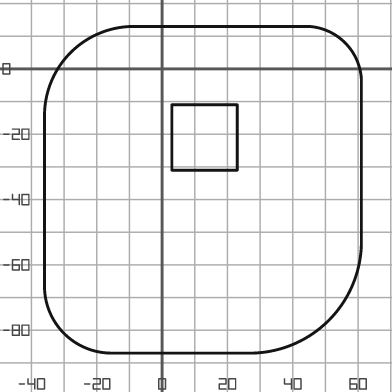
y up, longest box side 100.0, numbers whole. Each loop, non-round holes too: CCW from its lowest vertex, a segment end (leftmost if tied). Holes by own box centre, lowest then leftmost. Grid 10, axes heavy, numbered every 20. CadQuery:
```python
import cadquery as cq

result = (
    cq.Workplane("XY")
    .moveTo(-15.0, -87.0)
    .lineTo(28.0, -87.0)
    .threePointArc((51.0, -77.0), (61.0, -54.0))
    .lineTo(61.0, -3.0)
    .threePointArc((56.0, 8.0), (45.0, 13.0))
    .lineTo(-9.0, 13.0)
    .threePointArc((-28.0, 5.0), (-36.0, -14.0))
    .lineTo(-36.0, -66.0)
    .threePointArc((-30.0, -81.0), (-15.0, -87.0))
    .close()
    .moveTo(3.0, -31.0)
    .lineTo(23.0, -31.0)
    .lineTo(23.0, -11.0)
    .lineTo(3.0, -11.0)
    .close()
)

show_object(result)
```